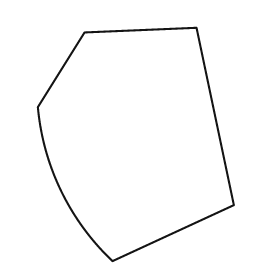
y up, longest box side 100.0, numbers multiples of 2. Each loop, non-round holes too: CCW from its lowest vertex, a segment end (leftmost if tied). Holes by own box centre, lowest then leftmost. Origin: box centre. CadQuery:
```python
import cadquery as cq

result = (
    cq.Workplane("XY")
    .moveTo(-10.0, -50.0)
    .lineTo(42.0, -26.0)
    .lineTo(26.0, 50.0)
    .lineTo(-22.0, 48.0)
    .lineTo(-42.0, 16.0)
    .threePointArc((-32.0, -20.0), (-10.0, -50.0))
    .close()
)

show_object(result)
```